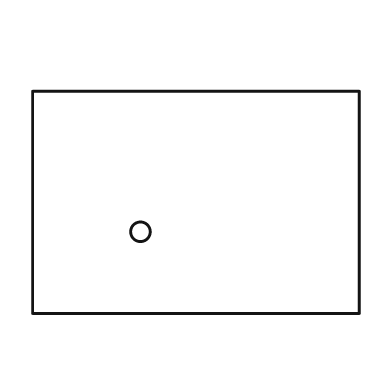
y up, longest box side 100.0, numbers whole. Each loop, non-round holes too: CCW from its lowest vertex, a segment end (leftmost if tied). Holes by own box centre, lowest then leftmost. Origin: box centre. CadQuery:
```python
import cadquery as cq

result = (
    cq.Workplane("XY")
    .moveTo(-50.0, -34.0)
    .lineTo(50.0, -34.0)
    .lineTo(50.0, 34.0)
    .lineTo(-50.0, 34.0)
    .close()
    .moveTo(-17.0, -9.0)
    .circle(3.0)
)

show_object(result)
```